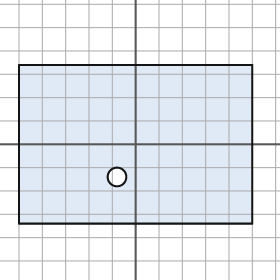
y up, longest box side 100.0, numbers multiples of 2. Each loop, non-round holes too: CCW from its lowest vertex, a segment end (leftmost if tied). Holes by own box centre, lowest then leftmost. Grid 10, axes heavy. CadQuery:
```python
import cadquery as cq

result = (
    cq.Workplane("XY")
    .moveTo(-50.0, -34.0)
    .lineTo(50.0, -34.0)
    .lineTo(50.0, 34.0)
    .lineTo(-50.0, 34.0)
    .close()
    .moveTo(-8.0, -14.0)
    .circle(4.0)
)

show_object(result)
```